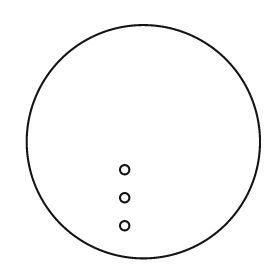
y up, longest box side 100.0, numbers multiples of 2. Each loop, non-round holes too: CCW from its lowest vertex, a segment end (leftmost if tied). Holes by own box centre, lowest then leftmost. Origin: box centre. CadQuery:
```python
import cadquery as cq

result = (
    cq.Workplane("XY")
    .moveTo(0.0, 0.0)
    .circle(50.0)
    .moveTo(-8.0, -36.0)
    .circle(2.0)
    .moveTo(-8.0, -24.0)
    .circle(2.0)
    .moveTo(-8.0, -12.0)
    .circle(2.0)
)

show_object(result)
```